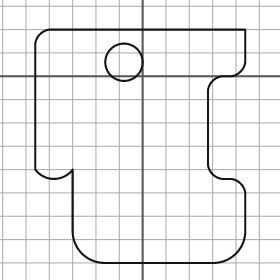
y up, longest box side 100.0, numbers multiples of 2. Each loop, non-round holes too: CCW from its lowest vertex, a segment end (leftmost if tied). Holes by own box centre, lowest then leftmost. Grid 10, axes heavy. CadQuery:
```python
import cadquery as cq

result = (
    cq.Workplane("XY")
    .moveTo(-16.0, -80.0)
    .lineTo(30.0, -80.0)
    .threePointArc((40.0, -76.0), (44.0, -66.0))
    .lineTo(44.0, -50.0)
    .threePointArc((42.0, -46.0), (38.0, -44.0))
    .lineTo(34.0, -44.0)
    .threePointArc((30.0, -42.0), (28.0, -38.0))
    .lineTo(28.0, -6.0)
    .threePointArc((30.0, -2.0), (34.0, 0.0))
    .lineTo(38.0, 0.0)
    .threePointArc((42.0, 2.0), (44.0, 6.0))
    .lineTo(44.0, 20.0)
    .lineTo(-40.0, 20.0)
    .threePointArc((-44.0, 18.0), (-46.0, 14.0))
    .lineTo(-46.0, -40.0)
    .threePointArc((-38.0, -44.0), (-30.0, -40.0))
    .lineTo(-30.0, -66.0)
    .threePointArc((-26.0, -76.0), (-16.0, -80.0))
    .close()
    .moveTo(-8.0, 6.0)
    .circle(8.0)
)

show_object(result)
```